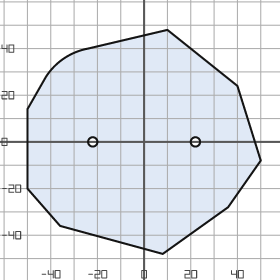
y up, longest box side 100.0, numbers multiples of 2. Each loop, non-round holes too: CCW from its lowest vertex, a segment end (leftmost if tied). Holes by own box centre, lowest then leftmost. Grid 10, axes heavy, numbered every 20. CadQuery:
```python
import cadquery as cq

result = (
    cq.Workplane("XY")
    .moveTo(8.0, -48.0)
    .lineTo(36.0, -28.0)
    .lineTo(50.0, -8.0)
    .lineTo(40.0, 24.0)
    .lineTo(10.0, 48.0)
    .lineTo(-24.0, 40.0)
    .threePointArc((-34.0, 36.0), (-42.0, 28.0))
    .lineTo(-50.0, 14.0)
    .lineTo(-50.0, -20.0)
    .lineTo(-36.0, -36.0)
    .close()
    .moveTo(-22.0, 0.0)
    .circle(2.0)
    .moveTo(22.0, 0.0)
    .circle(2.0)
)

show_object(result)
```